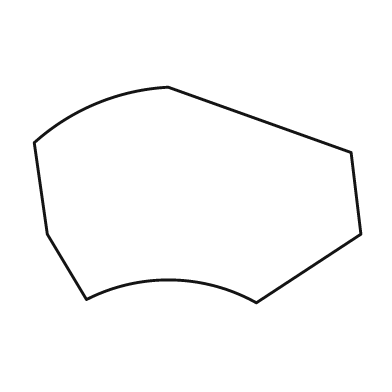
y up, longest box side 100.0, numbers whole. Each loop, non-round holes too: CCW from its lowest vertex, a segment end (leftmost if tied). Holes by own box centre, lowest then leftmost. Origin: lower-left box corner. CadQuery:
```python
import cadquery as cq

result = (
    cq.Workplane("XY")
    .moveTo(68.0, 0.0)
    .lineTo(100.0, 21.0)
    .lineTo(97.0, 46.0)
    .lineTo(41.0, 66.0)
    .threePointArc((19.0, 61.0), (0.0, 49.0))
    .lineTo(4.0, 21.0)
    .lineTo(16.0, 1.0)
    .threePointArc((42.0, 7.0), (68.0, 0.0))
    .close()
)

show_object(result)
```